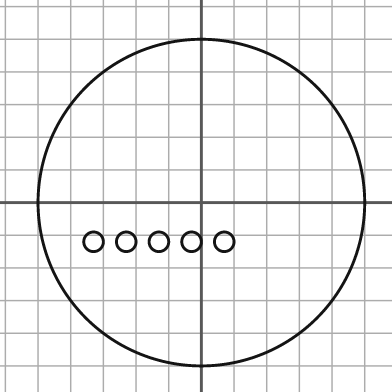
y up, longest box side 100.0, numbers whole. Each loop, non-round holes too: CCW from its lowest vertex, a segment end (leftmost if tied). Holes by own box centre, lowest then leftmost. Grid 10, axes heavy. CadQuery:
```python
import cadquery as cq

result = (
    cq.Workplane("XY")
    .moveTo(0.0, 0.0)
    .circle(50.0)
    .moveTo(-33.0, -12.0)
    .circle(3.0)
    .moveTo(-23.0, -12.0)
    .circle(3.0)
    .moveTo(-13.0, -12.0)
    .circle(3.0)
    .moveTo(-3.0, -12.0)
    .circle(3.0)
    .moveTo(7.0, -12.0)
    .circle(3.0)
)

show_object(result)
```